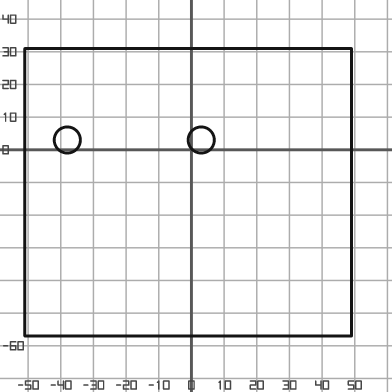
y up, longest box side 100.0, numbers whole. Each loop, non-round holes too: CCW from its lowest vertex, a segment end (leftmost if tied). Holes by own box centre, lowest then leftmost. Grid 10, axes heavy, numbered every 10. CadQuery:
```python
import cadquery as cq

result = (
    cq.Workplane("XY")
    .moveTo(-51.0, -57.0)
    .lineTo(49.0, -57.0)
    .lineTo(49.0, 31.0)
    .lineTo(-51.0, 31.0)
    .close()
    .moveTo(-38.0, 3.0)
    .circle(4.0)
    .moveTo(3.0, 3.0)
    .circle(4.0)
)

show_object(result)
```